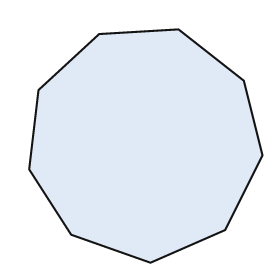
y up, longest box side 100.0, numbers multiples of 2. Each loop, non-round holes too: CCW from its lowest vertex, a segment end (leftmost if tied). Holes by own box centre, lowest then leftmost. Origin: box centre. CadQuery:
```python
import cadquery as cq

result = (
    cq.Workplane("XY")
    .moveTo(2.0, -50.0)
    .lineTo(34.0, -36.0)
    .lineTo(50.0, -4.0)
    .lineTo(42.0, 28.0)
    .lineTo(14.0, 50.0)
    .lineTo(-20.0, 48.0)
    .lineTo(-46.0, 24.0)
    .lineTo(-50.0, -10.0)
    .lineTo(-32.0, -38.0)
    .close()
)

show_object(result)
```